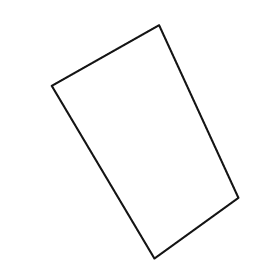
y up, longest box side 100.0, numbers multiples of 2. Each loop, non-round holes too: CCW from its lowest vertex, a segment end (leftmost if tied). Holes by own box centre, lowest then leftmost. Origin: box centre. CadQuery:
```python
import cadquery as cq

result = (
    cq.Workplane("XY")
    .moveTo(4.0, -50.0)
    .lineTo(40.0, -24.0)
    .lineTo(6.0, 50.0)
    .lineTo(-40.0, 24.0)
    .close()
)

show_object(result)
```